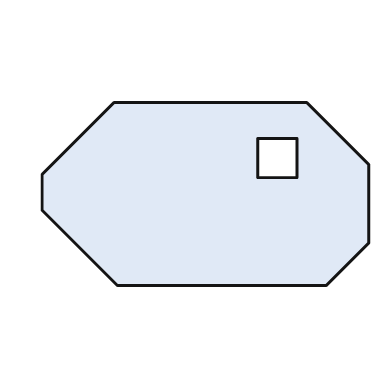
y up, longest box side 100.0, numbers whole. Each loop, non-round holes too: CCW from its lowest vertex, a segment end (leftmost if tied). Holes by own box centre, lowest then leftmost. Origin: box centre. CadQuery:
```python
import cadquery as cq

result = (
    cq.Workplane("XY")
    .moveTo(-27.0, -28.0)
    .lineTo(37.0, -28.0)
    .lineTo(50.0, -15.0)
    .lineTo(50.0, 9.0)
    .lineTo(31.0, 28.0)
    .lineTo(-28.0, 28.0)
    .lineTo(-50.0, 6.0)
    .lineTo(-50.0, -5.0)
    .close()
    .moveTo(16.0, 5.0)
    .lineTo(28.0, 5.0)
    .lineTo(28.0, 17.0)
    .lineTo(16.0, 17.0)
    .close()
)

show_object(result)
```